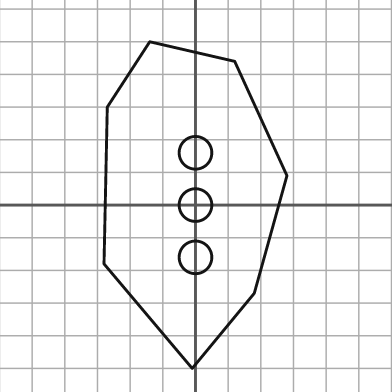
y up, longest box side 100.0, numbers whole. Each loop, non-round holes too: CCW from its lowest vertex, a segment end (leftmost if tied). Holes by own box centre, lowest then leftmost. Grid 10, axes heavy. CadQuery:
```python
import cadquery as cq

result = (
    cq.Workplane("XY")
    .moveTo(-1.0, -50.0)
    .lineTo(18.0, -27.0)
    .lineTo(28.0, 9.0)
    .lineTo(12.0, 44.0)
    .lineTo(-14.0, 50.0)
    .lineTo(-27.0, 30.0)
    .lineTo(-28.0, -18.0)
    .close()
    .moveTo(0.0, -16.0)
    .circle(5.0)
    .moveTo(0.0, 0.0)
    .circle(5.0)
    .moveTo(0.0, 16.0)
    .circle(5.0)
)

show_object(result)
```